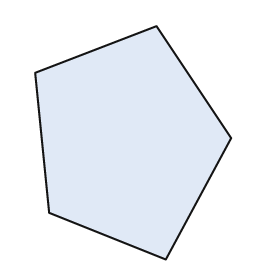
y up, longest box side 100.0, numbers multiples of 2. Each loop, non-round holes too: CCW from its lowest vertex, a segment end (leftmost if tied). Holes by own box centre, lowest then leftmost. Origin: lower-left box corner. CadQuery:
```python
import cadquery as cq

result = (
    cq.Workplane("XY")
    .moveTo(56.0, 0.0)
    .lineTo(84.0, 52.0)
    .lineTo(52.0, 100.0)
    .lineTo(0.0, 80.0)
    .lineTo(6.0, 20.0)
    .close()
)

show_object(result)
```